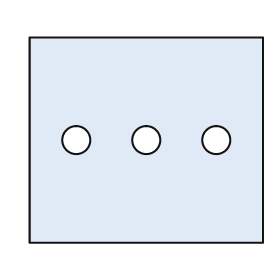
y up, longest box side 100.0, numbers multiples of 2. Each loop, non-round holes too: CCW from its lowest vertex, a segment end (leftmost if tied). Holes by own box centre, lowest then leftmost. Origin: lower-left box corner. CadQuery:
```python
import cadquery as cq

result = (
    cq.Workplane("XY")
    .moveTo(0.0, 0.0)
    .lineTo(100.0, 0.0)
    .lineTo(100.0, 88.0)
    .lineTo(0.0, 88.0)
    .close()
    .moveTo(20.0, 44.0)
    .circle(6.0)
    .moveTo(50.0, 44.0)
    .circle(6.0)
    .moveTo(80.0, 44.0)
    .circle(6.0)
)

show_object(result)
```